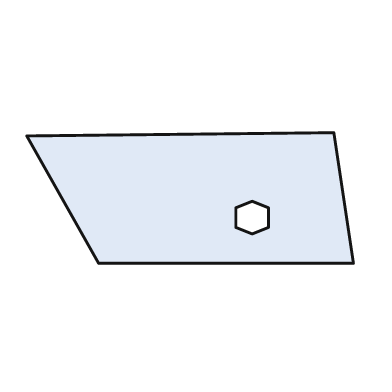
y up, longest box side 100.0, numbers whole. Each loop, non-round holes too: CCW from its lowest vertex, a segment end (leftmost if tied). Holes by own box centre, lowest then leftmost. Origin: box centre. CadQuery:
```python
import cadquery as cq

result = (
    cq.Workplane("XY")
    .moveTo(-28.0, -20.0)
    .lineTo(50.0, -20.0)
    .lineTo(44.0, 20.0)
    .lineTo(-50.0, 19.0)
    .close()
    .moveTo(19.0, -11.0)
    .lineTo(24.0, -9.0)
    .lineTo(24.0, -3.0)
    .lineTo(19.0, -1.0)
    .lineTo(14.0, -3.0)
    .lineTo(14.0, -9.0)
    .close()
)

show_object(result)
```